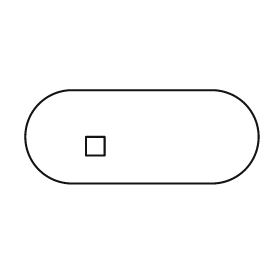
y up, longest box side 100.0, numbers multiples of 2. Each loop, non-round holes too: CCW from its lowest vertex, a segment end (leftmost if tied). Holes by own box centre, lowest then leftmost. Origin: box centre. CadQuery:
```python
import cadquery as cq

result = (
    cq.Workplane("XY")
    .moveTo(-30.0, -20.0)
    .lineTo(30.0, -20.0)
    .threePointArc((50.0, 0.0), (30.0, 20.0))
    .lineTo(-30.0, 20.0)
    .threePointArc((-50.0, 0.0), (-30.0, -20.0))
    .close()
    .moveTo(-24.0, -8.0)
    .lineTo(-16.0, -8.0)
    .lineTo(-16.0, 0.0)
    .lineTo(-24.0, 0.0)
    .close()
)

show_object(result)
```